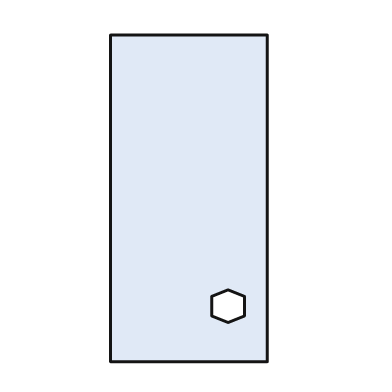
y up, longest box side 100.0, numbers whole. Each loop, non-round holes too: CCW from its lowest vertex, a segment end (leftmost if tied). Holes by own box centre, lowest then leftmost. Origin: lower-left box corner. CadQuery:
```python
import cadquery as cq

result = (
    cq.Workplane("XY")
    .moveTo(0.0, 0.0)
    .lineTo(48.0, 0.0)
    .lineTo(48.0, 100.0)
    .lineTo(0.0, 100.0)
    .close()
    .moveTo(36.0, 12.0)
    .lineTo(41.0, 14.0)
    .lineTo(41.0, 20.0)
    .lineTo(36.0, 22.0)
    .lineTo(31.0, 20.0)
    .lineTo(31.0, 14.0)
    .close()
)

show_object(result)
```